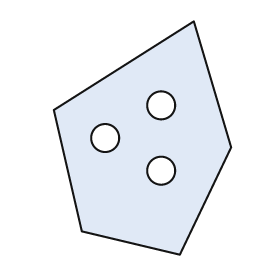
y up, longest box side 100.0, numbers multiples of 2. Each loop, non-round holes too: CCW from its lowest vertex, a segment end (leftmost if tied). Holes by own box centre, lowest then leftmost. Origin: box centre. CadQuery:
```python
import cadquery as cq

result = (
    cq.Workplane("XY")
    .moveTo(16.0, -50.0)
    .lineTo(38.0, -4.0)
    .lineTo(22.0, 50.0)
    .lineTo(-38.0, 12.0)
    .lineTo(-26.0, -40.0)
    .close()
    .moveTo(8.0, -14.0)
    .circle(6.0)
    .moveTo(-16.0, 0.0)
    .circle(6.0)
    .moveTo(8.0, 14.0)
    .circle(6.0)
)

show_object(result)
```